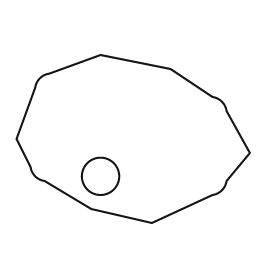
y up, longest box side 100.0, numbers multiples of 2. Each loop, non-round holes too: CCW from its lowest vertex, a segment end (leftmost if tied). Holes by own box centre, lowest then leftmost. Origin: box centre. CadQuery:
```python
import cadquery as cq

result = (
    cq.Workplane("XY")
    .moveTo(8.0, -36.0)
    .lineTo(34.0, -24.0)
    .threePointArc((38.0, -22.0), (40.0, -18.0))
    .lineTo(50.0, -6.0)
    .lineTo(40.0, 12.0)
    .threePointArc((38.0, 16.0), (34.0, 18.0))
    .lineTo(16.0, 30.0)
    .lineTo(-14.0, 36.0)
    .lineTo(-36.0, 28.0)
    .threePointArc((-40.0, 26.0), (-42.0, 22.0))
    .lineTo(-50.0, 0.0)
    .lineTo(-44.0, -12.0)
    .threePointArc((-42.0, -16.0), (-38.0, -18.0))
    .lineTo(-18.0, -30.0)
    .close()
    .moveTo(-14.0, -16.0)
    .circle(8.0)
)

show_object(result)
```